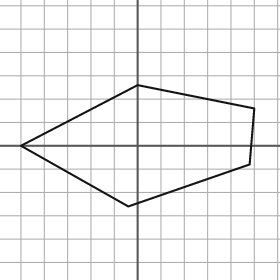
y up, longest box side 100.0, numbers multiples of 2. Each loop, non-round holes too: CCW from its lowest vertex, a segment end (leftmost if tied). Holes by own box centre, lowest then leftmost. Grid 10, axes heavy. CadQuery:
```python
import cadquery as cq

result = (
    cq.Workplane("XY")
    .moveTo(-4.0, -26.0)
    .lineTo(48.0, -8.0)
    .lineTo(50.0, 16.0)
    .lineTo(0.0, 26.0)
    .lineTo(-50.0, 0.0)
    .close()
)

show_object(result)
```